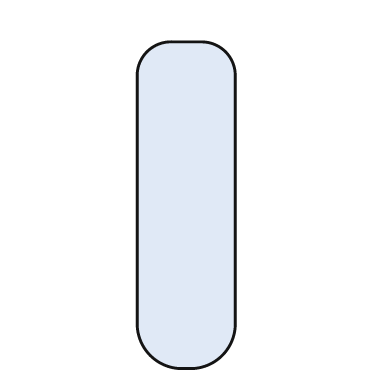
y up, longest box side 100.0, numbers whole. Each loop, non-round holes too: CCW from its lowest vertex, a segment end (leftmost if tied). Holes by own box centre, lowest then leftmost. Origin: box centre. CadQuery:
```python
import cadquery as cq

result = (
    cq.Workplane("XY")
    .moveTo(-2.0, -50.0)
    .lineTo(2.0, -50.0)
    .threePointArc((11.0, -46.0), (15.0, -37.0))
    .lineTo(15.0, 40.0)
    .threePointArc((12.0, 47.0), (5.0, 50.0))
    .lineTo(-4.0, 50.0)
    .threePointArc((-12.0, 47.0), (-15.0, 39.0))
    .lineTo(-15.0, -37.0)
    .threePointArc((-11.0, -46.0), (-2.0, -50.0))
    .close()
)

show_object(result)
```